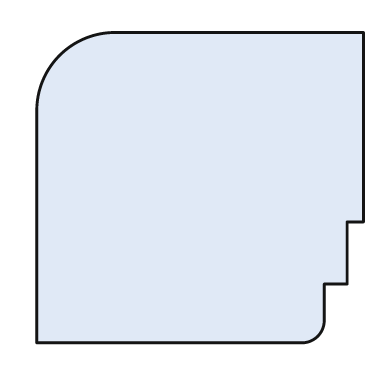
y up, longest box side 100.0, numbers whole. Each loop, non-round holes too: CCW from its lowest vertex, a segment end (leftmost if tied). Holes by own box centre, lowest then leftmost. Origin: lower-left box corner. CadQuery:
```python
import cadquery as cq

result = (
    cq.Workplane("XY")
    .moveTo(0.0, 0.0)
    .lineTo(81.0, 0.0)
    .threePointArc((86.0, 2.0), (88.0, 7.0))
    .lineTo(88.0, 18.0)
    .lineTo(95.0, 18.0)
    .lineTo(95.0, 37.0)
    .lineTo(100.0, 37.0)
    .lineTo(100.0, 95.0)
    .lineTo(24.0, 95.0)
    .threePointArc((7.0, 88.0), (0.0, 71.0))
    .close()
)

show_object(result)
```